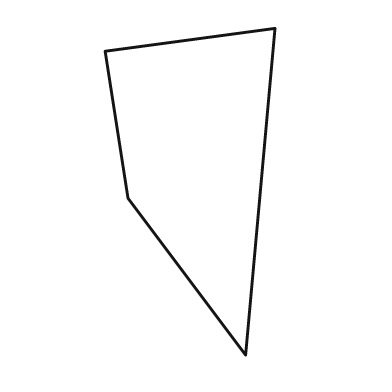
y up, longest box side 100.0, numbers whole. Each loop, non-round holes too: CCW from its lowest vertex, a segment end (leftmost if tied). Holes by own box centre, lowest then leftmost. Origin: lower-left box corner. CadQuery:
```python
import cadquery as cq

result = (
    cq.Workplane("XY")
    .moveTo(43.0, 0.0)
    .lineTo(52.0, 100.0)
    .lineTo(0.0, 93.0)
    .lineTo(7.0, 48.0)
    .close()
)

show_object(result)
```